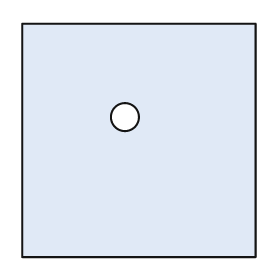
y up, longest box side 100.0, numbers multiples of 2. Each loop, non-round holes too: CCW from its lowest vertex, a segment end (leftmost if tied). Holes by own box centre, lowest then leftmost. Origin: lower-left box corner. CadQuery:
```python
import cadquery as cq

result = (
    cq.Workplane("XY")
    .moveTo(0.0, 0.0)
    .lineTo(100.0, 0.0)
    .lineTo(100.0, 100.0)
    .lineTo(0.0, 100.0)
    .close()
    .moveTo(44.0, 60.0)
    .circle(6.0)
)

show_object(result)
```